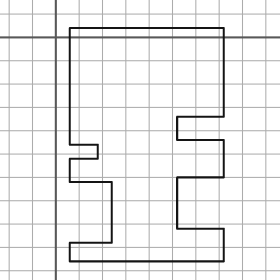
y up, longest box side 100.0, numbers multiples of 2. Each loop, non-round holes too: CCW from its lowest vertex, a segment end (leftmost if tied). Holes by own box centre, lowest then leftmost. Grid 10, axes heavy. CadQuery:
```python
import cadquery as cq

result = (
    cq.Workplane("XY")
    .moveTo(6.0, -96.0)
    .lineTo(72.0, -96.0)
    .lineTo(72.0, -82.0)
    .lineTo(52.0, -82.0)
    .lineTo(52.0, -60.0)
    .lineTo(72.0, -60.0)
    .lineTo(72.0, -44.0)
    .lineTo(52.0, -44.0)
    .lineTo(52.0, -34.0)
    .lineTo(72.0, -34.0)
    .lineTo(72.0, 4.0)
    .lineTo(6.0, 4.0)
    .lineTo(6.0, -46.0)
    .lineTo(18.0, -46.0)
    .lineTo(18.0, -52.0)
    .lineTo(6.0, -52.0)
    .lineTo(6.0, -62.0)
    .lineTo(24.0, -62.0)
    .lineTo(24.0, -88.0)
    .lineTo(6.0, -88.0)
    .close()
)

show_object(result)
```